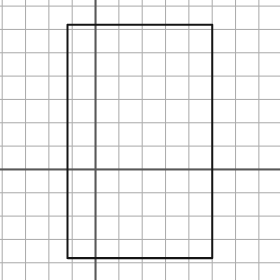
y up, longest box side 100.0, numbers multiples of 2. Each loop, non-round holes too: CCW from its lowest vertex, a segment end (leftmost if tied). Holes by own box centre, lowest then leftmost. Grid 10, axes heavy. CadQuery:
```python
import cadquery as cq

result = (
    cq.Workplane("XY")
    .moveTo(-12.0, -38.0)
    .lineTo(50.0, -38.0)
    .lineTo(50.0, 62.0)
    .lineTo(-12.0, 62.0)
    .close()
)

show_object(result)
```